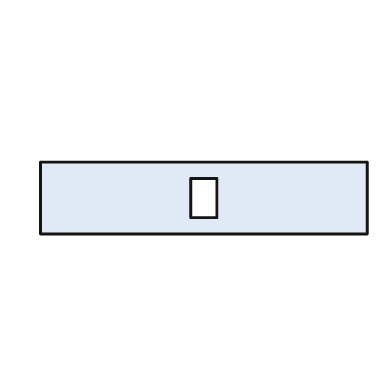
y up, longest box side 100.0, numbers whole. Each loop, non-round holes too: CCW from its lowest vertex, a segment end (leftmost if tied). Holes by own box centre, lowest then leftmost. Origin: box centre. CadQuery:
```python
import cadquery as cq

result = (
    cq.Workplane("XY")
    .moveTo(-50.0, -11.0)
    .lineTo(50.0, -11.0)
    .lineTo(50.0, 11.0)
    .lineTo(-50.0, 11.0)
    .close()
    .moveTo(-4.0, -6.0)
    .lineTo(4.0, -6.0)
    .lineTo(4.0, 6.0)
    .lineTo(-4.0, 6.0)
    .close()
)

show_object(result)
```